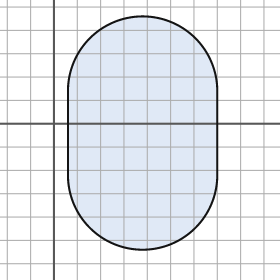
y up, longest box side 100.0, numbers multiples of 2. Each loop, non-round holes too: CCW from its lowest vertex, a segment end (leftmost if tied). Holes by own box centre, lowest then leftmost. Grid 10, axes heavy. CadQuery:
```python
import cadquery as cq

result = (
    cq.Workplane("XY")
    .moveTo(6.0, -22.0)
    .threePointArc((38.0, -54.0), (70.0, -22.0))
    .lineTo(70.0, 14.0)
    .threePointArc((38.0, 46.0), (6.0, 14.0))
    .close()
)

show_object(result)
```